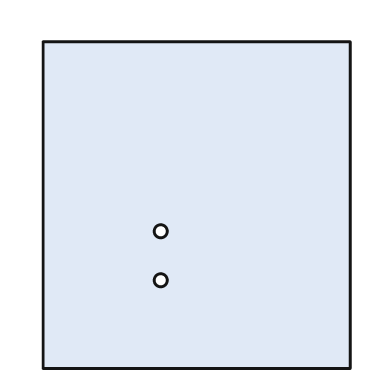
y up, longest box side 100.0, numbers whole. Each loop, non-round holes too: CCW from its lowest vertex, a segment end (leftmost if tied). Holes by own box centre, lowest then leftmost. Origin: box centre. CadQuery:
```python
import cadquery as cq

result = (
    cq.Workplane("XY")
    .moveTo(-47.0, -50.0)
    .lineTo(47.0, -50.0)
    .lineTo(47.0, 50.0)
    .lineTo(-47.0, 50.0)
    .close()
    .moveTo(-11.0, -23.0)
    .circle(2.0)
    .moveTo(-11.0, -8.0)
    .circle(2.0)
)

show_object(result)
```